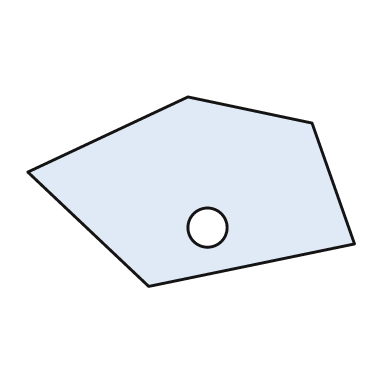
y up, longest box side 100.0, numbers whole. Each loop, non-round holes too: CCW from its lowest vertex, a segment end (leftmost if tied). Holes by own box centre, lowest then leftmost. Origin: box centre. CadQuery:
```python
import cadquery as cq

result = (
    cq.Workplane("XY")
    .moveTo(-13.0, -29.0)
    .lineTo(50.0, -16.0)
    .lineTo(37.0, 21.0)
    .lineTo(-1.0, 29.0)
    .lineTo(-50.0, 6.0)
    .close()
    .moveTo(5.0, -11.0)
    .circle(6.0)
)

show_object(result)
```